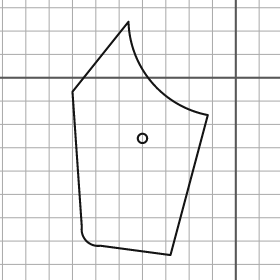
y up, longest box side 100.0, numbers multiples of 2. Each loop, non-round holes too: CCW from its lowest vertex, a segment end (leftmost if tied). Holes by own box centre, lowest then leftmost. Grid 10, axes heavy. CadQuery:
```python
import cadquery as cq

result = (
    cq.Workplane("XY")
    .moveTo(-28.0, -76.0)
    .lineTo(-12.0, -16.0)
    .threePointArc((-36.0, -2.0), (-46.0, 24.0))
    .lineTo(-70.0, -6.0)
    .lineTo(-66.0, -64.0)
    .threePointArc((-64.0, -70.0), (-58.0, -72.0))
    .close()
    .moveTo(-40.0, -26.0)
    .circle(2.0)
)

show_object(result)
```